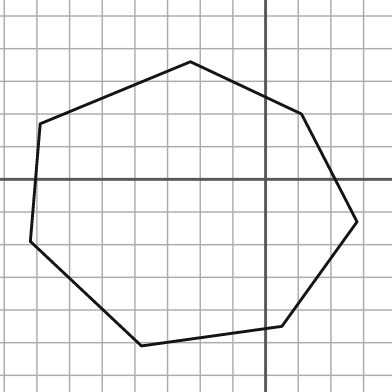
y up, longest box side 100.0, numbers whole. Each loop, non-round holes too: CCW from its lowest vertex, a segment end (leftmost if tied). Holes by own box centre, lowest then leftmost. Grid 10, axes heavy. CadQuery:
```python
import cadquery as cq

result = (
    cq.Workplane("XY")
    .moveTo(-38.0, -51.0)
    .lineTo(5.0, -45.0)
    .lineTo(28.0, -13.0)
    .lineTo(11.0, 20.0)
    .lineTo(-23.0, 36.0)
    .lineTo(-69.0, 17.0)
    .lineTo(-72.0, -19.0)
    .close()
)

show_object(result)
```